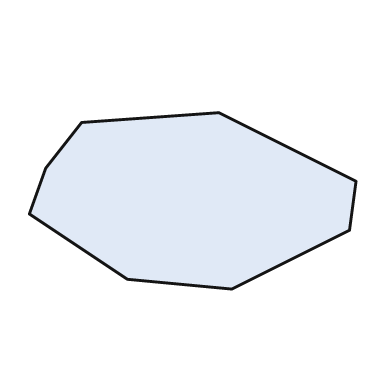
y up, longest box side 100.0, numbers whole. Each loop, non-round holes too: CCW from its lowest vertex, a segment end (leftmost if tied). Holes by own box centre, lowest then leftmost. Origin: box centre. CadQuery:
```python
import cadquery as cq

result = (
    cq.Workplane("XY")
    .moveTo(12.0, -27.0)
    .lineTo(48.0, -9.0)
    .lineTo(50.0, 6.0)
    .lineTo(8.0, 27.0)
    .lineTo(-34.0, 24.0)
    .lineTo(-45.0, 10.0)
    .lineTo(-50.0, -4.0)
    .lineTo(-20.0, -24.0)
    .close()
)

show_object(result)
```